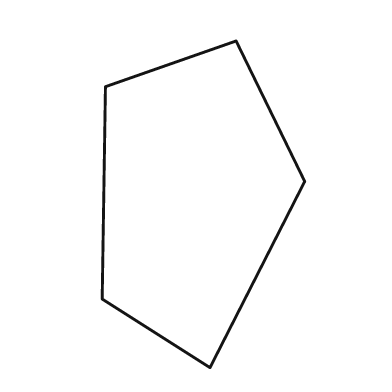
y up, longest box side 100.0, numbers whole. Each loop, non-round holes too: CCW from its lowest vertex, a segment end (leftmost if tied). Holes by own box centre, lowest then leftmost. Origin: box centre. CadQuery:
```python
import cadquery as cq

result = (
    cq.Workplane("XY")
    .moveTo(2.0, -50.0)
    .lineTo(31.0, 7.0)
    .lineTo(10.0, 50.0)
    .lineTo(-30.0, 36.0)
    .lineTo(-31.0, -29.0)
    .close()
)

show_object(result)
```